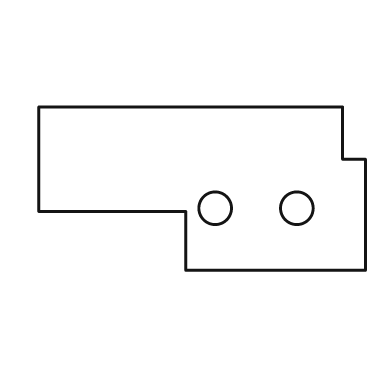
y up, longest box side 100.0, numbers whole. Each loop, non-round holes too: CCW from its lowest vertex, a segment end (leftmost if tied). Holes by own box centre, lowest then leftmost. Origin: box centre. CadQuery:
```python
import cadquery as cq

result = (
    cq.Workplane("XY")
    .moveTo(-5.0, -25.0)
    .lineTo(50.0, -25.0)
    .lineTo(50.0, 9.0)
    .lineTo(43.0, 9.0)
    .lineTo(43.0, 25.0)
    .lineTo(-50.0, 25.0)
    .lineTo(-50.0, -7.0)
    .lineTo(-5.0, -7.0)
    .close()
    .moveTo(4.0, -6.0)
    .circle(5.0)
    .moveTo(29.0, -6.0)
    .circle(5.0)
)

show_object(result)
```